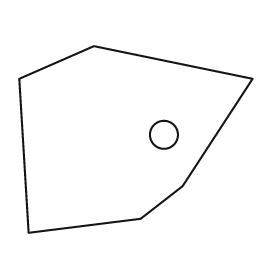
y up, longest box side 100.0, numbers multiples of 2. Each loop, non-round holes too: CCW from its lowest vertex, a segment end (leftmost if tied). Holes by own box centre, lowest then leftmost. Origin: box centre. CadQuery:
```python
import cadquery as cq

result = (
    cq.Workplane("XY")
    .moveTo(-46.0, -40.0)
    .lineTo(2.0, -34.0)
    .lineTo(20.0, -20.0)
    .lineTo(50.0, 26.0)
    .lineTo(-18.0, 40.0)
    .lineTo(-50.0, 26.0)
    .close()
    .moveTo(12.0, 2.0)
    .circle(6.0)
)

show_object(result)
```